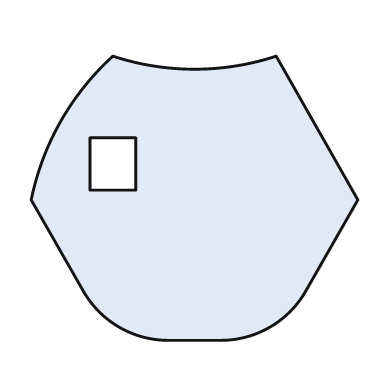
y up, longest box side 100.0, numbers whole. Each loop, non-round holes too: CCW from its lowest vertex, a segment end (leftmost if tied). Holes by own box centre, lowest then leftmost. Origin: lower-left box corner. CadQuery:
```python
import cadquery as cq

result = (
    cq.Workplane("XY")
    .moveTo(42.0, 0.0)
    .lineTo(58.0, 0.0)
    .threePointArc((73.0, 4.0), (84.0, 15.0))
    .lineTo(100.0, 43.0)
    .lineTo(75.0, 87.0)
    .threePointArc((50.0, 83.0), (25.0, 87.0))
    .threePointArc((9.0, 67.0), (0.0, 43.0))
    .lineTo(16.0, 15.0)
    .threePointArc((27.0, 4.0), (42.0, 0.0))
    .close()
    .moveTo(18.0, 46.0)
    .lineTo(32.0, 46.0)
    .lineTo(32.0, 62.0)
    .lineTo(18.0, 62.0)
    .close()
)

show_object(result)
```